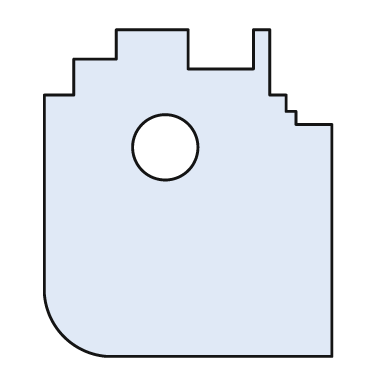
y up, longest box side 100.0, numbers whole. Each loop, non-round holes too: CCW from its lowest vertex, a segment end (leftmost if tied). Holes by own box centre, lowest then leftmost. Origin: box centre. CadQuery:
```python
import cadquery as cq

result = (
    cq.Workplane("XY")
    .moveTo(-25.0, -50.0)
    .lineTo(44.0, -50.0)
    .lineTo(44.0, 21.0)
    .lineTo(33.0, 21.0)
    .lineTo(33.0, 25.0)
    .lineTo(30.0, 25.0)
    .lineTo(30.0, 30.0)
    .lineTo(25.0, 30.0)
    .lineTo(25.0, 50.0)
    .lineTo(20.0, 50.0)
    .lineTo(20.0, 38.0)
    .lineTo(0.0, 38.0)
    .lineTo(0.0, 50.0)
    .lineTo(-22.0, 50.0)
    .lineTo(-22.0, 41.0)
    .lineTo(-35.0, 41.0)
    .lineTo(-35.0, 30.0)
    .lineTo(-44.0, 30.0)
    .lineTo(-44.0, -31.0)
    .threePointArc((-38.0, -44.0), (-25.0, -50.0))
    .close()
    .moveTo(-7.0, 14.0)
    .circle(10.0)
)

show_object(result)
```